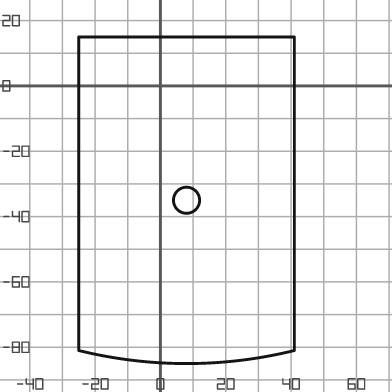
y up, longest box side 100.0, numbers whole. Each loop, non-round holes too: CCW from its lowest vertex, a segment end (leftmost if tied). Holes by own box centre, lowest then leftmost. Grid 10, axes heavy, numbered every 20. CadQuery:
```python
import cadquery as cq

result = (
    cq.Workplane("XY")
    .moveTo(-25.0, -81.0)
    .threePointArc((8.0, -85.0), (41.0, -81.0))
    .lineTo(41.0, 15.0)
    .lineTo(-25.0, 15.0)
    .close()
    .moveTo(8.0, -35.0)
    .circle(4.0)
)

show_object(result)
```